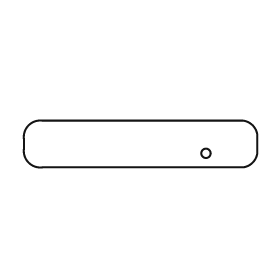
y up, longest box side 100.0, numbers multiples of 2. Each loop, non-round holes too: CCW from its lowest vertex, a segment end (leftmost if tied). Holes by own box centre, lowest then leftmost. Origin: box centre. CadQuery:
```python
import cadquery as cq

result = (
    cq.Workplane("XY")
    .moveTo(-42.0, -10.0)
    .lineTo(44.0, -10.0)
    .threePointArc((48.0, -8.0), (50.0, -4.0))
    .lineTo(50.0, 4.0)
    .threePointArc((48.0, 8.0), (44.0, 10.0))
    .lineTo(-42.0, 10.0)
    .threePointArc((-48.0, 8.0), (-50.0, 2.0))
    .lineTo(-50.0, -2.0)
    .threePointArc((-48.0, -8.0), (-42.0, -10.0))
    .close()
    .moveTo(28.0, -4.0)
    .circle(2.0)
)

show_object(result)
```